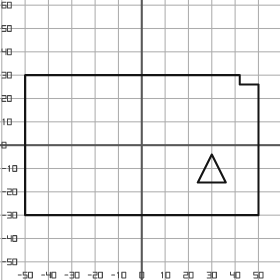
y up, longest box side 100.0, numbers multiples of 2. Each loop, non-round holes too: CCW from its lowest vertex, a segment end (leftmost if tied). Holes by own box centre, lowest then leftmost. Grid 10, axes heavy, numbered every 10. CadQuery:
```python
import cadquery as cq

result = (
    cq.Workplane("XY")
    .moveTo(-50.0, -30.0)
    .lineTo(50.0, -30.0)
    .lineTo(50.0, 26.0)
    .lineTo(42.0, 26.0)
    .lineTo(42.0, 30.0)
    .lineTo(-50.0, 30.0)
    .close()
    .moveTo(24.0, -16.0)
    .lineTo(36.0, -16.0)
    .lineTo(30.0, -4.0)
    .close()
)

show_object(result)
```